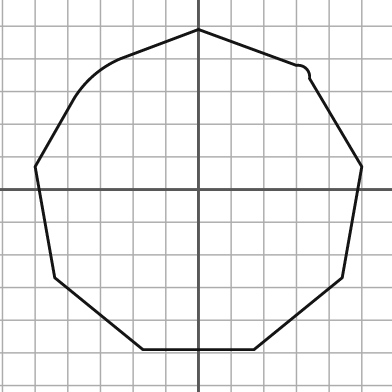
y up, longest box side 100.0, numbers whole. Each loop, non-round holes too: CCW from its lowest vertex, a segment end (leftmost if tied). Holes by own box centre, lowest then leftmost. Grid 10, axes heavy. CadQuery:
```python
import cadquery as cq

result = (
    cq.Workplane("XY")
    .moveTo(-17.0, -49.0)
    .lineTo(17.0, -49.0)
    .lineTo(44.0, -27.0)
    .lineTo(50.0, 7.0)
    .lineTo(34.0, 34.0)
    .threePointArc((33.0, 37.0), (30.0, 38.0))
    .lineTo(0.0, 49.0)
    .lineTo(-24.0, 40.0)
    .threePointArc((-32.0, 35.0), (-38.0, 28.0))
    .lineTo(-50.0, 7.0)
    .lineTo(-44.0, -27.0)
    .close()
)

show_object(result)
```